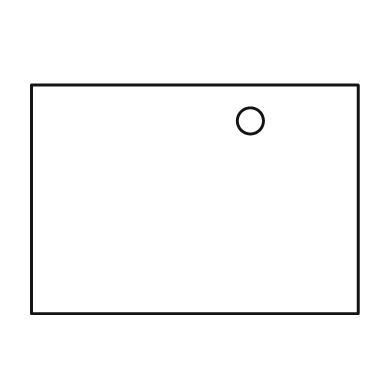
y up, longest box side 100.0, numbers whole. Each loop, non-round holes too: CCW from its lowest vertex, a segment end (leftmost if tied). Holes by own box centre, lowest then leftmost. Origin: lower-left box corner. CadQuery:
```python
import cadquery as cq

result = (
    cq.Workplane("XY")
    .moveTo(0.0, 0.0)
    .lineTo(100.0, 0.0)
    .lineTo(100.0, 70.0)
    .lineTo(0.0, 70.0)
    .close()
    .moveTo(67.0, 59.0)
    .circle(4.0)
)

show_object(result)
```